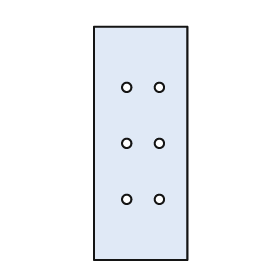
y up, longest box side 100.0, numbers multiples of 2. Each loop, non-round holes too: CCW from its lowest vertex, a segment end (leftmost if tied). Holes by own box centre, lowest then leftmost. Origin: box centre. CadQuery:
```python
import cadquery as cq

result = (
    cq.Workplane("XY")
    .moveTo(-20.0, -50.0)
    .lineTo(20.0, -50.0)
    .lineTo(20.0, 50.0)
    .lineTo(-20.0, 50.0)
    .close()
    .moveTo(-6.0, -24.0)
    .circle(2.0)
    .moveTo(8.0, -24.0)
    .circle(2.0)
    .moveTo(-6.0, 0.0)
    .circle(2.0)
    .moveTo(8.0, 0.0)
    .circle(2.0)
    .moveTo(-6.0, 24.0)
    .circle(2.0)
    .moveTo(8.0, 24.0)
    .circle(2.0)
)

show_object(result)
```